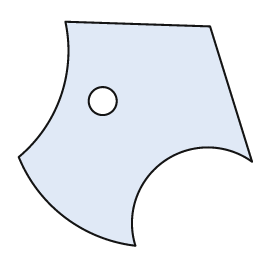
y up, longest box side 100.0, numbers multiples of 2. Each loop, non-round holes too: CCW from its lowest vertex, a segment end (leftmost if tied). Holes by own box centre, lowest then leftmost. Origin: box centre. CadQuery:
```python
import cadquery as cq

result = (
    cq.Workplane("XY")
    .moveTo(0.0, -48.0)
    .threePointArc((12.0, -12.0), (50.0, -12.0))
    .lineTo(32.0, 46.0)
    .lineTo(-30.0, 48.0)
    .threePointArc((-32.0, 16.0), (-50.0, -10.0))
    .threePointArc((-30.0, -36.0), (0.0, -48.0))
    .close()
    .moveTo(-14.0, 14.0)
    .circle(6.0)
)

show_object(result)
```